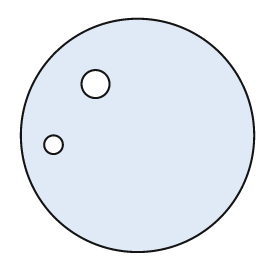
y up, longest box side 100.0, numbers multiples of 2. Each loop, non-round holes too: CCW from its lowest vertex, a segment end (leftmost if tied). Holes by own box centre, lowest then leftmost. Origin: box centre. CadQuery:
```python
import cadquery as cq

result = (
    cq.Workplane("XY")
    .moveTo(0.0, 0.0)
    .circle(50.0)
    .moveTo(-36.0, -4.0)
    .circle(4.0)
    .moveTo(-18.0, 22.0)
    .circle(6.0)
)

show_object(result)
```